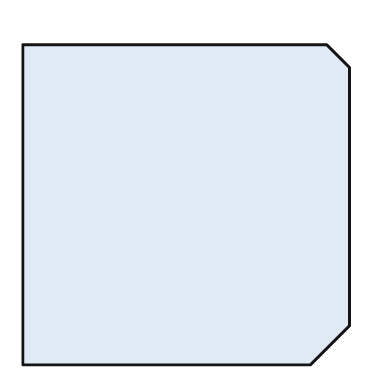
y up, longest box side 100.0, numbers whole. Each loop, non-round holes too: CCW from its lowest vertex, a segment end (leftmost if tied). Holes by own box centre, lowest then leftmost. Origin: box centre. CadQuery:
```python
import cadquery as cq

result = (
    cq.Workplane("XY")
    .moveTo(-50.0, -49.0)
    .lineTo(38.0, -49.0)
    .lineTo(50.0, -37.0)
    .lineTo(50.0, 42.0)
    .lineTo(43.0, 49.0)
    .lineTo(-50.0, 49.0)
    .close()
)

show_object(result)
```